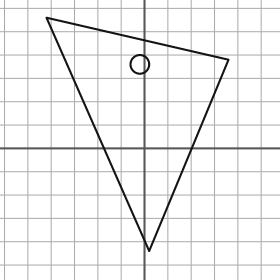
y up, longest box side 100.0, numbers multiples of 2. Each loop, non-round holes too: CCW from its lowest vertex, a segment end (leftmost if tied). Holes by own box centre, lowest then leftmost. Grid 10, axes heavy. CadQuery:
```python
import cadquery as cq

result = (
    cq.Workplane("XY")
    .moveTo(2.0, -44.0)
    .lineTo(36.0, 38.0)
    .lineTo(-42.0, 56.0)
    .close()
    .moveTo(-2.0, 36.0)
    .circle(4.0)
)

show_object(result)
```